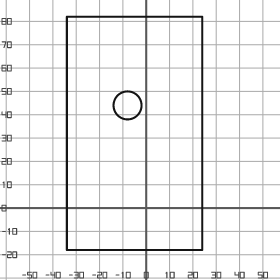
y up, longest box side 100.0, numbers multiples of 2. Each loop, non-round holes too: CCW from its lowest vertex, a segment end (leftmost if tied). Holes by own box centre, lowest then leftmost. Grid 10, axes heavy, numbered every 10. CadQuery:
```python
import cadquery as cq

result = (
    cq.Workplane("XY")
    .moveTo(-34.0, -18.0)
    .lineTo(24.0, -18.0)
    .lineTo(24.0, 82.0)
    .lineTo(-34.0, 82.0)
    .close()
    .moveTo(-8.0, 44.0)
    .circle(6.0)
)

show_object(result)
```